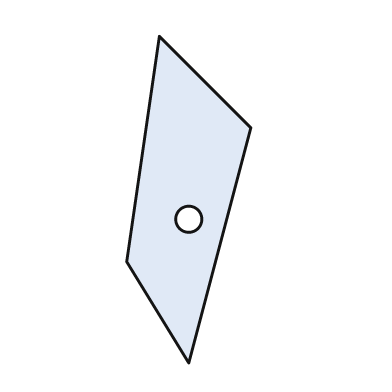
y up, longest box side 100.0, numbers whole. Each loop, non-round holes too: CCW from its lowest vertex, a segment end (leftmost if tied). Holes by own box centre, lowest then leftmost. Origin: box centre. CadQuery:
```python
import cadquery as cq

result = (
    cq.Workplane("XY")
    .moveTo(0.0, -50.0)
    .lineTo(19.0, 22.0)
    .lineTo(-9.0, 50.0)
    .lineTo(-19.0, -19.0)
    .close()
    .moveTo(0.0, -6.0)
    .circle(4.0)
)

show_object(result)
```